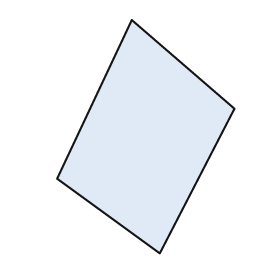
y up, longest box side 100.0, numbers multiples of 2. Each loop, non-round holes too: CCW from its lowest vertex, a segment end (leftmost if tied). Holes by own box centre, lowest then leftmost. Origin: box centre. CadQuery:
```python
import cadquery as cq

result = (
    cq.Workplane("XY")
    .moveTo(6.0, -50.0)
    .lineTo(38.0, 12.0)
    .lineTo(-6.0, 50.0)
    .lineTo(-38.0, -18.0)
    .close()
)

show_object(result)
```